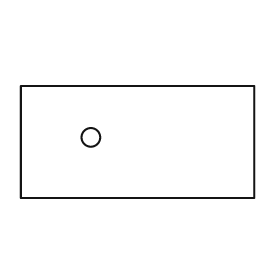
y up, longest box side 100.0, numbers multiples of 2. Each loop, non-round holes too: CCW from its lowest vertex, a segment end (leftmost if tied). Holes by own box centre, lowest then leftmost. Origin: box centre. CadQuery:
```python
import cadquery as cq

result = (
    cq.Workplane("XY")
    .moveTo(-50.0, -24.0)
    .lineTo(50.0, -24.0)
    .lineTo(50.0, 24.0)
    .lineTo(-50.0, 24.0)
    .close()
    .moveTo(-20.0, 2.0)
    .circle(4.0)
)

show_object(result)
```